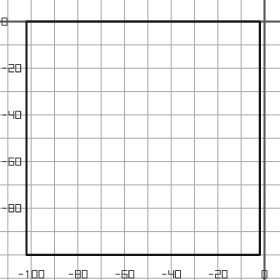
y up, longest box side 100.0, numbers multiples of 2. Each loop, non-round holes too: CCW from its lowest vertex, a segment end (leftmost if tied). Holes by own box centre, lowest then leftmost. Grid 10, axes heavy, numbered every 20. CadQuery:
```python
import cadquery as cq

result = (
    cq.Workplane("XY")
    .moveTo(-102.0, -100.0)
    .lineTo(-2.0, -100.0)
    .lineTo(-2.0, 0.0)
    .lineTo(-102.0, 0.0)
    .close()
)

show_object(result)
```